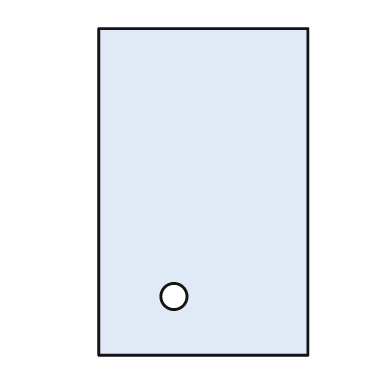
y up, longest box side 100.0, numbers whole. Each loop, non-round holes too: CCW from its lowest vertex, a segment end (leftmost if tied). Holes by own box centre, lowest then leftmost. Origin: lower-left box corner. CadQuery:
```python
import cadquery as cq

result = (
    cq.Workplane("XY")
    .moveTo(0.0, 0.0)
    .lineTo(64.0, 0.0)
    .lineTo(64.0, 100.0)
    .lineTo(0.0, 100.0)
    .close()
    .moveTo(23.0, 18.0)
    .circle(4.0)
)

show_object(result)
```